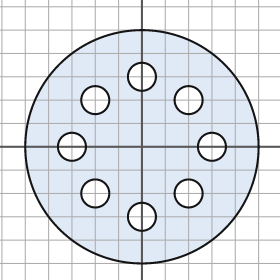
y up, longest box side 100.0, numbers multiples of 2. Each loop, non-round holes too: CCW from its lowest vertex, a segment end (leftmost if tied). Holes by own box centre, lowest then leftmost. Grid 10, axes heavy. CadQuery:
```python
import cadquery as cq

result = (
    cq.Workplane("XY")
    .moveTo(0.0, 0.0)
    .circle(50.0)
    .moveTo(0.0, -30.0)
    .circle(6.0)
    .moveTo(-20.0, -20.0)
    .circle(6.0)
    .moveTo(20.0, -20.0)
    .circle(6.0)
    .moveTo(-30.0, 0.0)
    .circle(6.0)
    .moveTo(30.0, 0.0)
    .circle(6.0)
    .moveTo(-20.0, 20.0)
    .circle(6.0)
    .moveTo(20.0, 20.0)
    .circle(6.0)
    .moveTo(0.0, 30.0)
    .circle(6.0)
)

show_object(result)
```